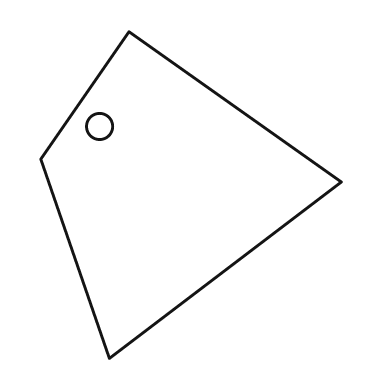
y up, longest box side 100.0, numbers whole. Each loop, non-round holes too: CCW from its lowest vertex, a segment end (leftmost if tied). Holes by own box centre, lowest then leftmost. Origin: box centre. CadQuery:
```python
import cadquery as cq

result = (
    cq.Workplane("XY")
    .moveTo(-25.0, -50.0)
    .lineTo(46.0, 4.0)
    .lineTo(-19.0, 50.0)
    .lineTo(-46.0, 11.0)
    .close()
    .moveTo(-28.0, 21.0)
    .circle(4.0)
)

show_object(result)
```